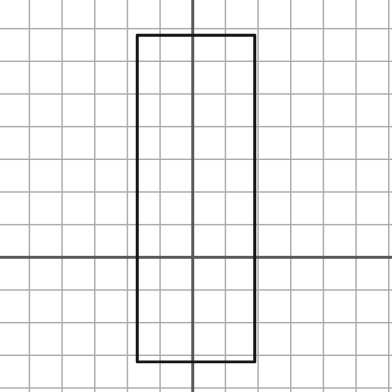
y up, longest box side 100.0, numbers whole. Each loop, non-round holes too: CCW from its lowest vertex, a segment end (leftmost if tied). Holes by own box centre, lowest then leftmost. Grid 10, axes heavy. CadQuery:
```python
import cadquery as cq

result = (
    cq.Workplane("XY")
    .moveTo(-17.0, -32.0)
    .lineTo(19.0, -32.0)
    .lineTo(19.0, 68.0)
    .lineTo(-17.0, 68.0)
    .close()
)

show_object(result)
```